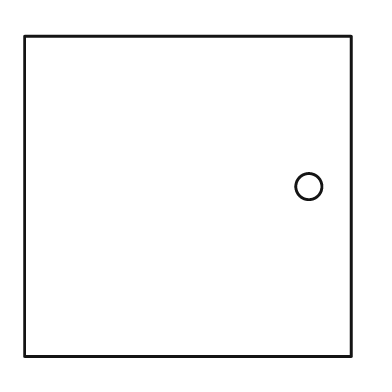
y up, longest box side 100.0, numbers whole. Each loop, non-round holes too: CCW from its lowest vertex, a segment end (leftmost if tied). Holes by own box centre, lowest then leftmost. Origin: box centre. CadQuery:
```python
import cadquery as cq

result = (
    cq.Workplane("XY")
    .moveTo(-50.0, -49.0)
    .lineTo(50.0, -49.0)
    .lineTo(50.0, 49.0)
    .lineTo(-50.0, 49.0)
    .close()
    .moveTo(37.0, 3.0)
    .circle(4.0)
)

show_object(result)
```